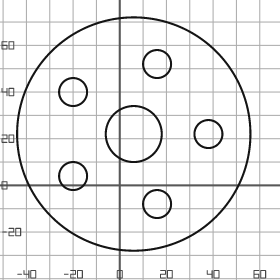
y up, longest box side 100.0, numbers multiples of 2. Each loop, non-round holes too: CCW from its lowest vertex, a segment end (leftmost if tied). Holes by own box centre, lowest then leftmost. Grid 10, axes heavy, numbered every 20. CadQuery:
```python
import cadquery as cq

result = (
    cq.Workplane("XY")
    .moveTo(6.0, 22.0)
    .circle(50.0)
    .moveTo(16.0, -8.0)
    .circle(6.0)
    .moveTo(-20.0, 4.0)
    .circle(6.0)
    .moveTo(6.0, 22.0)
    .circle(12.0)
    .moveTo(38.0, 22.0)
    .circle(6.0)
    .moveTo(-20.0, 40.0)
    .circle(6.0)
    .moveTo(16.0, 52.0)
    .circle(6.0)
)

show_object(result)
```